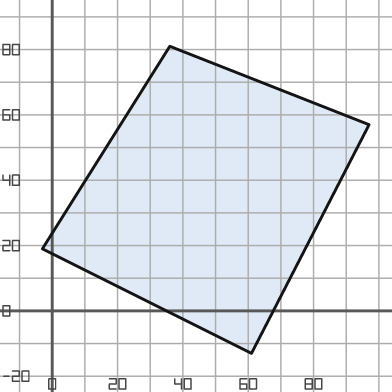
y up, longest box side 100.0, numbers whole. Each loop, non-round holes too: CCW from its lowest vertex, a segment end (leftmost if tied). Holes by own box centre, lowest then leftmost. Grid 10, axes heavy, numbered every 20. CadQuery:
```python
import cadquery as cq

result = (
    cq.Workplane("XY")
    .moveTo(61.0, -13.0)
    .lineTo(97.0, 57.0)
    .lineTo(36.0, 81.0)
    .lineTo(-3.0, 19.0)
    .close()
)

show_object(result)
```